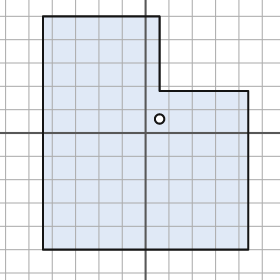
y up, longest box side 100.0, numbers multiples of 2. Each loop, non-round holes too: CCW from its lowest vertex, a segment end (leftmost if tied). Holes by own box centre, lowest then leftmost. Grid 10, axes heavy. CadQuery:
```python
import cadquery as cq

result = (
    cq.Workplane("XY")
    .moveTo(-44.0, -50.0)
    .lineTo(44.0, -50.0)
    .lineTo(44.0, 18.0)
    .lineTo(6.0, 18.0)
    .lineTo(6.0, 50.0)
    .lineTo(-44.0, 50.0)
    .close()
    .moveTo(6.0, 6.0)
    .circle(2.0)
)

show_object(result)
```